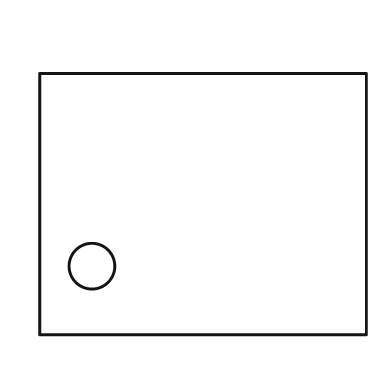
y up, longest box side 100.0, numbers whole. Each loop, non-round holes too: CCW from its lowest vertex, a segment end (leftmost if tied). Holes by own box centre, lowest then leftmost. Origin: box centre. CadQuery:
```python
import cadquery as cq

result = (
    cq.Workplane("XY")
    .moveTo(-50.0, -40.0)
    .lineTo(50.0, -40.0)
    .lineTo(50.0, 40.0)
    .lineTo(-50.0, 40.0)
    .close()
    .moveTo(-34.0, -19.0)
    .circle(7.0)
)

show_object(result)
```